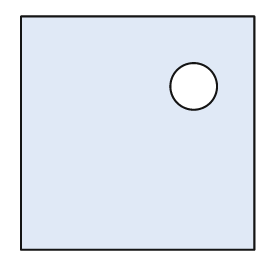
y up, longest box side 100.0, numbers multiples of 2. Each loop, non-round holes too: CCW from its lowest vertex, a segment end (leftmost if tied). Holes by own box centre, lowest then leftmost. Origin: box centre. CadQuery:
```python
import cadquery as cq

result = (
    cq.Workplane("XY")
    .moveTo(-50.0, -50.0)
    .lineTo(50.0, -50.0)
    .lineTo(50.0, 50.0)
    .lineTo(-50.0, 50.0)
    .close()
    .moveTo(24.0, 20.0)
    .circle(10.0)
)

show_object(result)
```